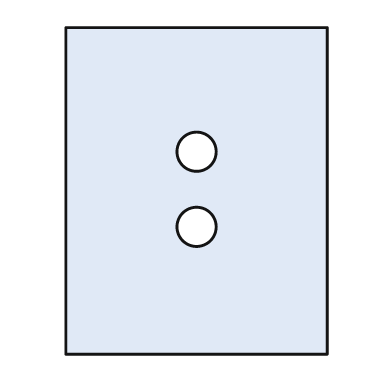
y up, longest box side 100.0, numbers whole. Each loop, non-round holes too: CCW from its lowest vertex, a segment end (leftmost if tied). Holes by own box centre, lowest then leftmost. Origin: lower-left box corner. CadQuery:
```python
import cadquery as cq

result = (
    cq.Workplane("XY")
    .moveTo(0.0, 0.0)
    .lineTo(80.0, 0.0)
    .lineTo(80.0, 100.0)
    .lineTo(0.0, 100.0)
    .close()
    .moveTo(40.0, 39.0)
    .circle(6.0)
    .moveTo(40.0, 62.0)
    .circle(6.0)
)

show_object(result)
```